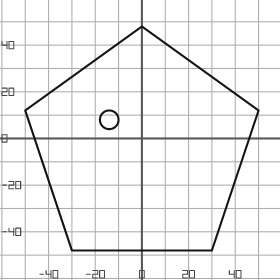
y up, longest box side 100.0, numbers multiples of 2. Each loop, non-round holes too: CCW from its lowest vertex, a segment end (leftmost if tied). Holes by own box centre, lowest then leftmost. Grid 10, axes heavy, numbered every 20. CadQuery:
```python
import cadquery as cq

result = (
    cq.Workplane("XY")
    .moveTo(-30.0, -48.0)
    .lineTo(30.0, -48.0)
    .lineTo(50.0, 12.0)
    .lineTo(0.0, 48.0)
    .lineTo(-50.0, 12.0)
    .close()
    .moveTo(-14.0, 8.0)
    .circle(4.0)
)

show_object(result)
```